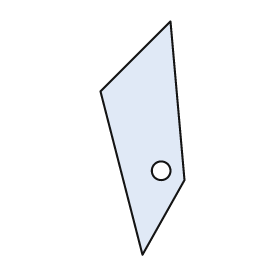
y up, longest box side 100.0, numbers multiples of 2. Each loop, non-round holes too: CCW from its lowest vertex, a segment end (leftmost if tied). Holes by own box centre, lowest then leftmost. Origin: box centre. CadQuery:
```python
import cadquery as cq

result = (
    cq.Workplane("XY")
    .moveTo(0.0, -50.0)
    .lineTo(18.0, -18.0)
    .lineTo(12.0, 50.0)
    .lineTo(-18.0, 20.0)
    .close()
    .moveTo(8.0, -14.0)
    .circle(4.0)
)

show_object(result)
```